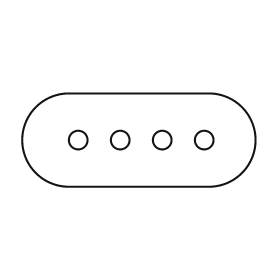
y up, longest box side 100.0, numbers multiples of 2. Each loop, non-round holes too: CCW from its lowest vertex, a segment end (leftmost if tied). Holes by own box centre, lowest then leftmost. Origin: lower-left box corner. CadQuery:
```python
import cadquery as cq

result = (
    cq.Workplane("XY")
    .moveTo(20.0, 0.0)
    .lineTo(80.0, 0.0)
    .threePointArc((100.0, 20.0), (80.0, 40.0))
    .lineTo(20.0, 40.0)
    .threePointArc((0.0, 20.0), (20.0, 0.0))
    .close()
    .moveTo(24.0, 20.0)
    .circle(4.0)
    .moveTo(42.0, 20.0)
    .circle(4.0)
    .moveTo(60.0, 20.0)
    .circle(4.0)
    .moveTo(78.0, 20.0)
    .circle(4.0)
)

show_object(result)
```